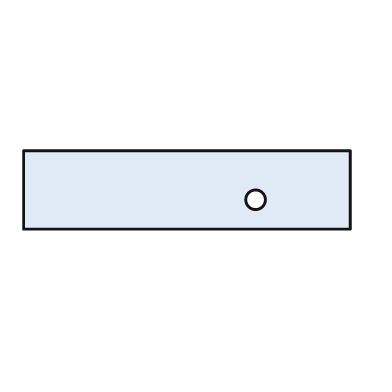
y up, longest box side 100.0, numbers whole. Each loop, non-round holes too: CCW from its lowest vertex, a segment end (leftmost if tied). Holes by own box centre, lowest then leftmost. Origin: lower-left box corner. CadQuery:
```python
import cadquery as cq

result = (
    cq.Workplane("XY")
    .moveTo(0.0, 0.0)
    .lineTo(100.0, 0.0)
    .lineTo(100.0, 24.0)
    .lineTo(0.0, 24.0)
    .close()
    .moveTo(71.0, 9.0)
    .circle(3.0)
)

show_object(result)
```